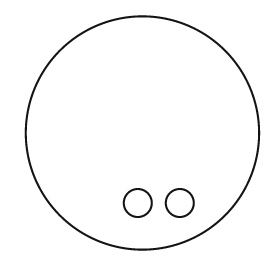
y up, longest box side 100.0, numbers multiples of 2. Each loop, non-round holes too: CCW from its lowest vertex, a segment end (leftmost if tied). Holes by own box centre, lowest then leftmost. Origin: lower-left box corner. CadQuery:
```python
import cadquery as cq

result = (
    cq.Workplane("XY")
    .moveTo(50.0, 50.0)
    .circle(50.0)
    .moveTo(48.0, 20.0)
    .circle(6.0)
    .moveTo(66.0, 20.0)
    .circle(6.0)
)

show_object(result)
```